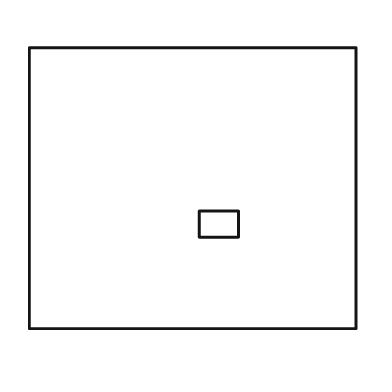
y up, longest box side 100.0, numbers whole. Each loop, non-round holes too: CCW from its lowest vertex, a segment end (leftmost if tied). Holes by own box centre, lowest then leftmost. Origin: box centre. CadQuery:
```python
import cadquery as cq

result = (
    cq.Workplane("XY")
    .moveTo(-50.0, -43.0)
    .lineTo(50.0, -43.0)
    .lineTo(50.0, 43.0)
    .lineTo(-50.0, 43.0)
    .close()
    .moveTo(2.0, -15.0)
    .lineTo(14.0, -15.0)
    .lineTo(14.0, -7.0)
    .lineTo(2.0, -7.0)
    .close()
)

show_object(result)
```